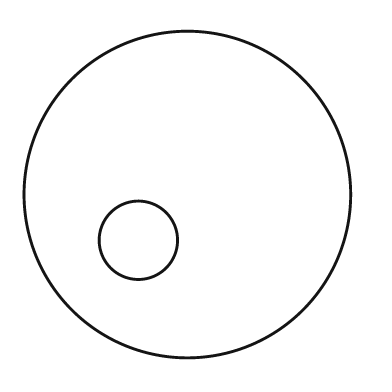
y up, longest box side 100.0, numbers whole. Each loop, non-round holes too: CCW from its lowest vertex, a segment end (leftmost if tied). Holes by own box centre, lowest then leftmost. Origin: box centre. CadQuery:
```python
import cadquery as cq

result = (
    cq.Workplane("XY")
    .moveTo(0.0, 0.0)
    .circle(50.0)
    .moveTo(-15.0, -14.0)
    .circle(12.0)
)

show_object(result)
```